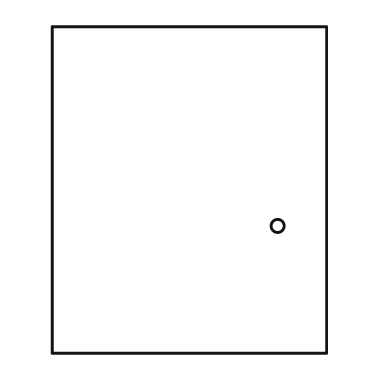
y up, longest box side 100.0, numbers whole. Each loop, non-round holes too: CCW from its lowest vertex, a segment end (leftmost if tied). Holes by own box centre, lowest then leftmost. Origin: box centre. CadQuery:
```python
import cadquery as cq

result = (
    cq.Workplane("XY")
    .moveTo(-42.0, -50.0)
    .lineTo(42.0, -50.0)
    .lineTo(42.0, 50.0)
    .lineTo(-42.0, 50.0)
    .close()
    .moveTo(27.0, -11.0)
    .circle(2.0)
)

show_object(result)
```